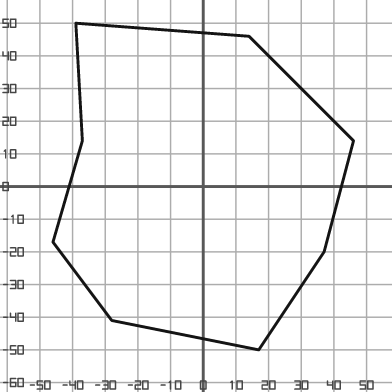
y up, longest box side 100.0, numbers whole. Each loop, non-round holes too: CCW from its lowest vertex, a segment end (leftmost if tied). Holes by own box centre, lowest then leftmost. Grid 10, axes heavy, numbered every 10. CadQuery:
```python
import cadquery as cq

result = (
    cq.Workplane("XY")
    .moveTo(17.0, -50.0)
    .lineTo(37.0, -20.0)
    .lineTo(46.0, 14.0)
    .lineTo(14.0, 46.0)
    .lineTo(-39.0, 50.0)
    .lineTo(-37.0, 14.0)
    .lineTo(-46.0, -17.0)
    .lineTo(-28.0, -41.0)
    .close()
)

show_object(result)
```